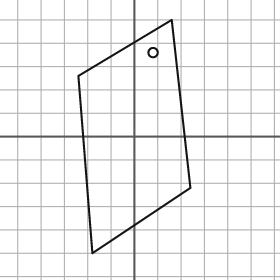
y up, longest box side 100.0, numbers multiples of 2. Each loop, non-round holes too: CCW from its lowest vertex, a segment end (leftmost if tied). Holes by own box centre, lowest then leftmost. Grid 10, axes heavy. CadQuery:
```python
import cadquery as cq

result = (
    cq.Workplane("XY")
    .moveTo(-18.0, -50.0)
    .lineTo(24.0, -22.0)
    .lineTo(16.0, 50.0)
    .lineTo(-24.0, 26.0)
    .close()
    .moveTo(8.0, 36.0)
    .circle(2.0)
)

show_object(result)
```